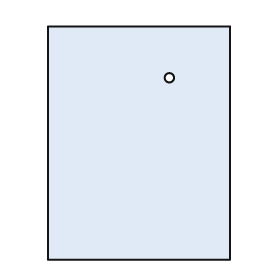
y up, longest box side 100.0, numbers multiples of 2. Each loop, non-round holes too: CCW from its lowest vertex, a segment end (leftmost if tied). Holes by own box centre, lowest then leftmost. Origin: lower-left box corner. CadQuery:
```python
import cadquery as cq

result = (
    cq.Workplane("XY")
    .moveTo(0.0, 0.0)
    .lineTo(78.0, 0.0)
    .lineTo(78.0, 100.0)
    .lineTo(0.0, 100.0)
    .close()
    .moveTo(52.0, 78.0)
    .circle(2.0)
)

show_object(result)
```